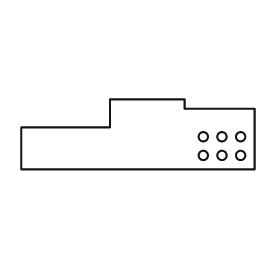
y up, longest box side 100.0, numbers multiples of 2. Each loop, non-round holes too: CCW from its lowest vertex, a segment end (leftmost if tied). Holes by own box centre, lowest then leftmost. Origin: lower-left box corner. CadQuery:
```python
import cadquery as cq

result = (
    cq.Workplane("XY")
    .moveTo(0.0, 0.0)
    .lineTo(100.0, 0.0)
    .lineTo(100.0, 26.0)
    .lineTo(70.0, 26.0)
    .lineTo(70.0, 30.0)
    .lineTo(38.0, 30.0)
    .lineTo(38.0, 18.0)
    .lineTo(0.0, 18.0)
    .close()
    .moveTo(78.0, 6.0)
    .circle(2.0)
    .moveTo(86.0, 6.0)
    .circle(2.0)
    .moveTo(94.0, 6.0)
    .circle(2.0)
    .moveTo(78.0, 14.0)
    .circle(2.0)
    .moveTo(86.0, 14.0)
    .circle(2.0)
    .moveTo(94.0, 14.0)
    .circle(2.0)
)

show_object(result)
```